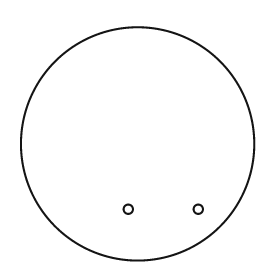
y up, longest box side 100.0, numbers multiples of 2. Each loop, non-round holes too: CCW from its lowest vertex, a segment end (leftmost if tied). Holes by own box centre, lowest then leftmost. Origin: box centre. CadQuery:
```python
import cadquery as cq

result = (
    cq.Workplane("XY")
    .moveTo(0.0, 0.0)
    .circle(50.0)
    .moveTo(-4.0, -28.0)
    .circle(2.0)
    .moveTo(26.0, -28.0)
    .circle(2.0)
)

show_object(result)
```